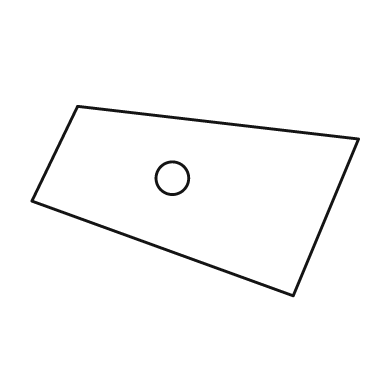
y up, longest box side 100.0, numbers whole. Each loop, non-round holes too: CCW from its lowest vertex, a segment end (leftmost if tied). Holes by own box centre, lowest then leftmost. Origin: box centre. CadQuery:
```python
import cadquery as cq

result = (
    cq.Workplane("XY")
    .moveTo(30.0, -29.0)
    .lineTo(50.0, 19.0)
    .lineTo(-36.0, 29.0)
    .lineTo(-50.0, 0.0)
    .close()
    .moveTo(-7.0, 7.0)
    .circle(5.0)
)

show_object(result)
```